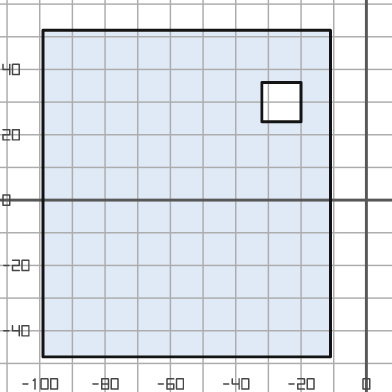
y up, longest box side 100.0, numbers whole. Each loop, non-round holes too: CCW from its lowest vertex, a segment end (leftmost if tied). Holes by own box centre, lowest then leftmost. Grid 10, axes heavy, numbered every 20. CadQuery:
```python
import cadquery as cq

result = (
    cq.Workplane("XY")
    .moveTo(-99.0, -48.0)
    .lineTo(-11.0, -48.0)
    .lineTo(-11.0, 52.0)
    .lineTo(-99.0, 52.0)
    .close()
    .moveTo(-32.0, 24.0)
    .lineTo(-20.0, 24.0)
    .lineTo(-20.0, 36.0)
    .lineTo(-32.0, 36.0)
    .close()
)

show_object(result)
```